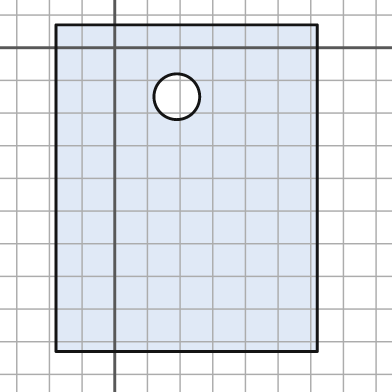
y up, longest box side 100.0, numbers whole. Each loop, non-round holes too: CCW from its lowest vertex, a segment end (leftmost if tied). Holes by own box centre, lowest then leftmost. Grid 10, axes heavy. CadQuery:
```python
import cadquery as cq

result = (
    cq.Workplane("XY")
    .moveTo(-18.0, -93.0)
    .lineTo(62.0, -93.0)
    .lineTo(62.0, 7.0)
    .lineTo(-18.0, 7.0)
    .close()
    .moveTo(19.0, -15.0)
    .circle(7.0)
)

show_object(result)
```